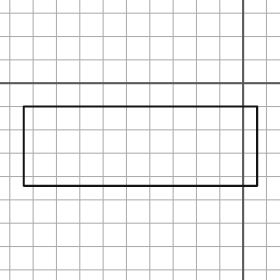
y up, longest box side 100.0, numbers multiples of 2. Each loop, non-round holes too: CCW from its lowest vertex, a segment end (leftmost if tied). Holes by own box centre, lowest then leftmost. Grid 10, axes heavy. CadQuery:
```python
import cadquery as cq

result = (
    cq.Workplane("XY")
    .moveTo(-94.0, -44.0)
    .lineTo(6.0, -44.0)
    .lineTo(6.0, -10.0)
    .lineTo(-94.0, -10.0)
    .close()
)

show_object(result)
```